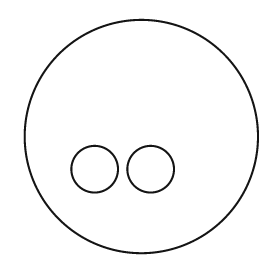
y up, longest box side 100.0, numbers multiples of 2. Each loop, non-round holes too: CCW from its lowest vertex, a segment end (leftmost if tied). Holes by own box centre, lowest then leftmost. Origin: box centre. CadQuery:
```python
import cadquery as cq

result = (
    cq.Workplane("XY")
    .moveTo(0.0, 0.0)
    .circle(50.0)
    .moveTo(-20.0, -14.0)
    .circle(10.0)
    .moveTo(4.0, -14.0)
    .circle(10.0)
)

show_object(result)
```